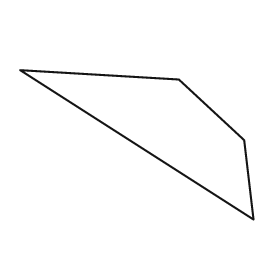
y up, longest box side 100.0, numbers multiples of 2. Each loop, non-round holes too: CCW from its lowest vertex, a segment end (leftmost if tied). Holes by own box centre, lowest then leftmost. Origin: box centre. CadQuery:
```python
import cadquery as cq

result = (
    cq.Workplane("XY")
    .moveTo(50.0, -32.0)
    .lineTo(46.0, 2.0)
    .lineTo(18.0, 28.0)
    .lineTo(-50.0, 32.0)
    .close()
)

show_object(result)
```